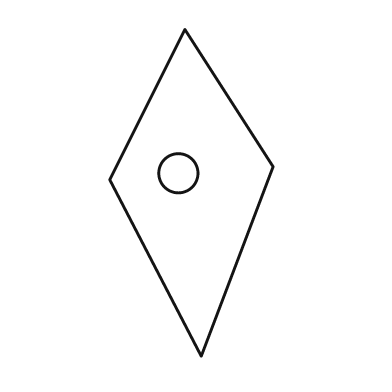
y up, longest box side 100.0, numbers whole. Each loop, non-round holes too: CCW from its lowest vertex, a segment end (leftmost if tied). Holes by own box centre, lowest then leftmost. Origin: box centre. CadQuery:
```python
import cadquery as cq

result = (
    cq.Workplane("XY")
    .moveTo(3.0, -50.0)
    .lineTo(25.0, 8.0)
    .lineTo(-2.0, 50.0)
    .lineTo(-25.0, 4.0)
    .close()
    .moveTo(-4.0, 6.0)
    .circle(6.0)
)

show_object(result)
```